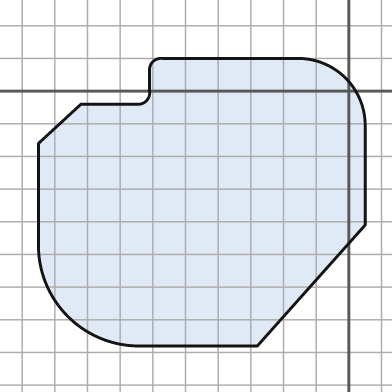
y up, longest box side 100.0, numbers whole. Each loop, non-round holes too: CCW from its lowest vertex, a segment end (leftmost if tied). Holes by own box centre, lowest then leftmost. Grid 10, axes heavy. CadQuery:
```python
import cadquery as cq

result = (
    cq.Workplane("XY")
    .moveTo(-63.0, -78.0)
    .lineTo(-28.0, -78.0)
    .lineTo(5.0, -41.0)
    .lineTo(5.0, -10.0)
    .threePointArc((-1.0, 4.0), (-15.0, 10.0))
    .lineTo(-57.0, 10.0)
    .threePointArc((-60.0, 9.0), (-61.0, 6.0))
    .lineTo(-61.0, 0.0)
    .threePointArc((-62.0, -3.0), (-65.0, -4.0))
    .lineTo(-82.0, -4.0)
    .lineTo(-95.0, -16.0)
    .lineTo(-95.0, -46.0)
    .threePointArc((-86.0, -69.0), (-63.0, -78.0))
    .close()
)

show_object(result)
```